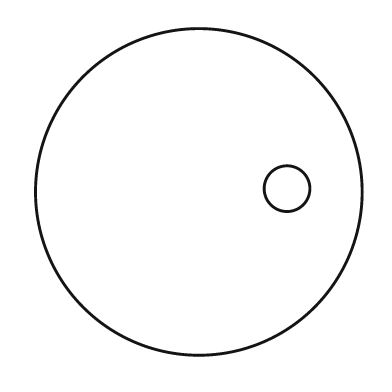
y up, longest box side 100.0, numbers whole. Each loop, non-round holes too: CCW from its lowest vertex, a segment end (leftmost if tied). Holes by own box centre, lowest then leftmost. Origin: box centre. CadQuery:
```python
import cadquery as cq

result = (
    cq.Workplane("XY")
    .moveTo(0.0, 0.0)
    .circle(50.0)
    .moveTo(27.0, 1.0)
    .circle(7.0)
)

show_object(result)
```